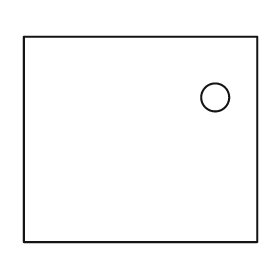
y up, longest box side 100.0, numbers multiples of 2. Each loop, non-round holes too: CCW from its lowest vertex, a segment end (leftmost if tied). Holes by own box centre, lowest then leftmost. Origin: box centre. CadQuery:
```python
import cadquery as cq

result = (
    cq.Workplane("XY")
    .moveTo(-50.0, -44.0)
    .lineTo(50.0, -44.0)
    .lineTo(50.0, 44.0)
    .lineTo(-50.0, 44.0)
    .close()
    .moveTo(32.0, 18.0)
    .circle(6.0)
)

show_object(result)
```